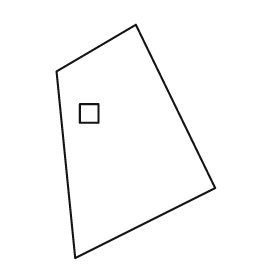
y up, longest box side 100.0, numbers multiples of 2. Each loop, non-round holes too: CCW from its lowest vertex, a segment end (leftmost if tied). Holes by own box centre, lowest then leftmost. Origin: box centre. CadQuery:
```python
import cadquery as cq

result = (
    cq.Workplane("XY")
    .moveTo(-26.0, -50.0)
    .lineTo(34.0, -20.0)
    .lineTo(0.0, 50.0)
    .lineTo(-34.0, 30.0)
    .close()
    .moveTo(-24.0, 8.0)
    .lineTo(-16.0, 8.0)
    .lineTo(-16.0, 16.0)
    .lineTo(-24.0, 16.0)
    .close()
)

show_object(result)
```